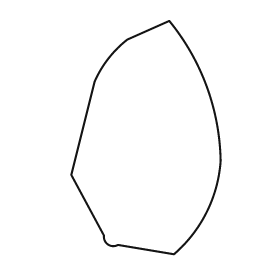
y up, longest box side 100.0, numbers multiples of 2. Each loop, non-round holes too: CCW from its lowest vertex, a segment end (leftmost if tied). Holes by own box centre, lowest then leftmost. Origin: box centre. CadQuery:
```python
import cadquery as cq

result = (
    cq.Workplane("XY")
    .moveTo(12.0, -50.0)
    .threePointArc((26.0, -32.0), (32.0, -10.0))
    .threePointArc((26.0, 22.0), (10.0, 50.0))
    .lineTo(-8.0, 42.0)
    .threePointArc((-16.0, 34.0), (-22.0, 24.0))
    .lineTo(-32.0, -16.0)
    .lineTo(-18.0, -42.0)
    .threePointArc((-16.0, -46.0), (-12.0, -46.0))
    .close()
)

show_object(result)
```